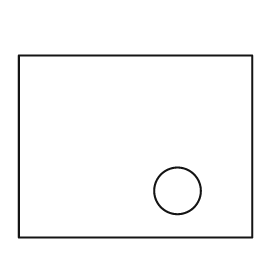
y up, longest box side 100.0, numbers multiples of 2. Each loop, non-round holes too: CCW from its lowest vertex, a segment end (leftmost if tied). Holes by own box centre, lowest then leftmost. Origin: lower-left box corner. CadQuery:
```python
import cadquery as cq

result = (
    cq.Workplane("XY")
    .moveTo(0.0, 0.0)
    .lineTo(100.0, 0.0)
    .lineTo(100.0, 78.0)
    .lineTo(0.0, 78.0)
    .close()
    .moveTo(68.0, 20.0)
    .circle(10.0)
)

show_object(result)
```